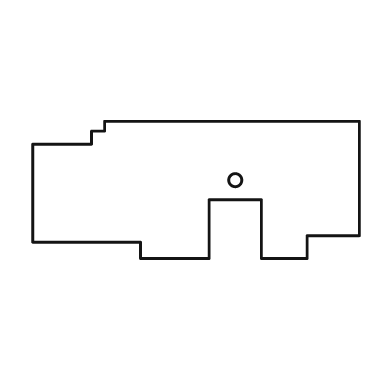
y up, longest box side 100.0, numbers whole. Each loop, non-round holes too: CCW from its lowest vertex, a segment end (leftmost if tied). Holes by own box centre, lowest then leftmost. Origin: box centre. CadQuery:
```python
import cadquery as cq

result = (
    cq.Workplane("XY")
    .moveTo(-17.0, -21.0)
    .lineTo(4.0, -21.0)
    .lineTo(4.0, -3.0)
    .lineTo(20.0, -3.0)
    .lineTo(20.0, -21.0)
    .lineTo(34.0, -21.0)
    .lineTo(34.0, -14.0)
    .lineTo(50.0, -14.0)
    .lineTo(50.0, 21.0)
    .lineTo(-28.0, 21.0)
    .lineTo(-28.0, 18.0)
    .lineTo(-32.0, 18.0)
    .lineTo(-32.0, 14.0)
    .lineTo(-50.0, 14.0)
    .lineTo(-50.0, -16.0)
    .lineTo(-17.0, -16.0)
    .close()
    .moveTo(12.0, 3.0)
    .circle(2.0)
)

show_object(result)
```